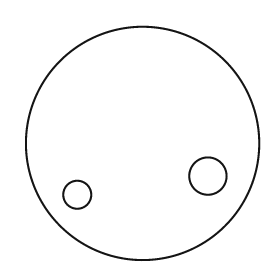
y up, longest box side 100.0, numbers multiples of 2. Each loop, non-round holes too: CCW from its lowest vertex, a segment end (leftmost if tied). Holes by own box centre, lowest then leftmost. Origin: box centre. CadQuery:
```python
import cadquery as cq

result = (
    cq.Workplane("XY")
    .moveTo(0.0, 0.0)
    .circle(50.0)
    .moveTo(-28.0, -22.0)
    .circle(6.0)
    .moveTo(28.0, -14.0)
    .circle(8.0)
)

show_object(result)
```